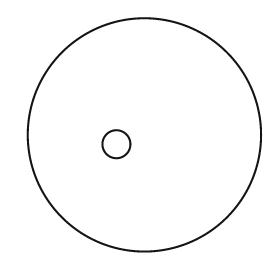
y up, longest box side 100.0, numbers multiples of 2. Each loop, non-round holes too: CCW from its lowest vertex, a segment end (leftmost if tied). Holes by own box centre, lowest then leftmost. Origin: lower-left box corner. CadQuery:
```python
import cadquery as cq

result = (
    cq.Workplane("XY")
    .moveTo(50.0, 50.0)
    .circle(50.0)
    .moveTo(38.0, 46.0)
    .circle(6.0)
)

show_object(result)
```